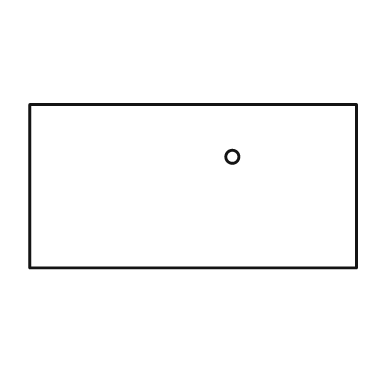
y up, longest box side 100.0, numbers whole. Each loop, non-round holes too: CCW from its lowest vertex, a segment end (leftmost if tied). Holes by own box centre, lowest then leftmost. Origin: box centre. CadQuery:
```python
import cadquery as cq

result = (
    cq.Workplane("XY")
    .moveTo(-50.0, -25.0)
    .lineTo(50.0, -25.0)
    .lineTo(50.0, 25.0)
    .lineTo(-50.0, 25.0)
    .close()
    .moveTo(12.0, 9.0)
    .circle(2.0)
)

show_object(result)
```